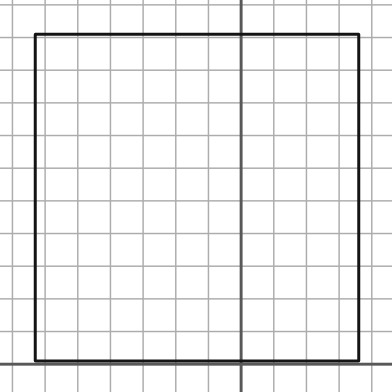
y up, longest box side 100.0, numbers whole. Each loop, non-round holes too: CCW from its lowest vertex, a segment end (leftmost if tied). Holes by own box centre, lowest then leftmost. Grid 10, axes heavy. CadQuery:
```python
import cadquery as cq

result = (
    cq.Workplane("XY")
    .moveTo(-63.0, 1.0)
    .lineTo(36.0, 1.0)
    .lineTo(36.0, 101.0)
    .lineTo(-63.0, 101.0)
    .close()
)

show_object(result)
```